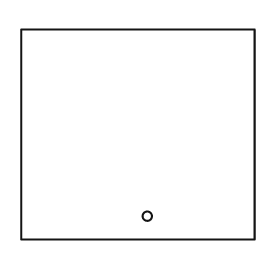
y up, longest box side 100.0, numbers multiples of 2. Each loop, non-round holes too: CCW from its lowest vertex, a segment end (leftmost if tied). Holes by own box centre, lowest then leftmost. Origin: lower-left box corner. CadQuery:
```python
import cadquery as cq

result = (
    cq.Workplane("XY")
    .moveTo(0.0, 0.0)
    .lineTo(100.0, 0.0)
    .lineTo(100.0, 90.0)
    .lineTo(0.0, 90.0)
    .close()
    .moveTo(54.0, 10.0)
    .circle(2.0)
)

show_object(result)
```